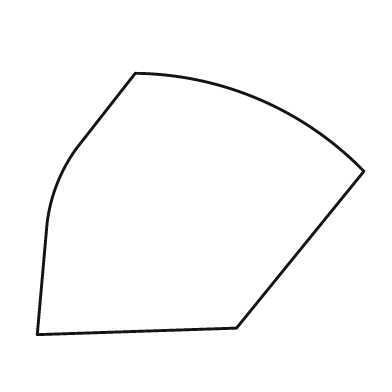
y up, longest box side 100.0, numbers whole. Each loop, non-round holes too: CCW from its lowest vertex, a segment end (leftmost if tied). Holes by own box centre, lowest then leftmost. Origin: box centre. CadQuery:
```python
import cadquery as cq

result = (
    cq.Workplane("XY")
    .moveTo(-50.0, -40.0)
    .lineTo(11.0, -38.0)
    .lineTo(50.0, 10.0)
    .threePointArc((18.0, 32.0), (-20.0, 40.0))
    .lineTo(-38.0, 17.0)
    .threePointArc((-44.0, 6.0), (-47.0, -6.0))
    .close()
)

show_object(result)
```